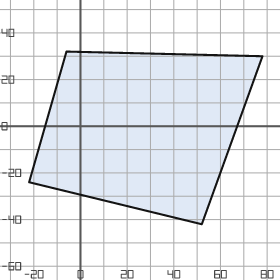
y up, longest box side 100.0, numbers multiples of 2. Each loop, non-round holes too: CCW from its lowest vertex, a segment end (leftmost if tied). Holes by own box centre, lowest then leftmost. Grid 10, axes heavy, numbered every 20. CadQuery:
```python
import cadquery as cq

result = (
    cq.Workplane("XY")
    .moveTo(52.0, -42.0)
    .lineTo(78.0, 30.0)
    .lineTo(-6.0, 32.0)
    .lineTo(-22.0, -24.0)
    .close()
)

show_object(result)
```